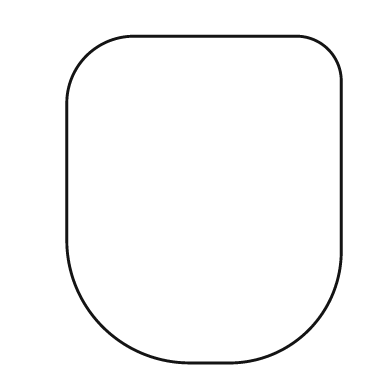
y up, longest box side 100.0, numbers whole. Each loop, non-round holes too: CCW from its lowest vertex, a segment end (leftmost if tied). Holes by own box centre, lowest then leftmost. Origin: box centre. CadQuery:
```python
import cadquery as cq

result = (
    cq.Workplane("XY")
    .moveTo(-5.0, -50.0)
    .lineTo(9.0, -50.0)
    .threePointArc((32.0, -40.0), (42.0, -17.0))
    .lineTo(42.0, 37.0)
    .threePointArc((38.0, 46.0), (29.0, 50.0))
    .lineTo(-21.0, 50.0)
    .threePointArc((-36.0, 44.0), (-42.0, 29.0))
    .lineTo(-42.0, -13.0)
    .threePointArc((-31.0, -39.0), (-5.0, -50.0))
    .close()
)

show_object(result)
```